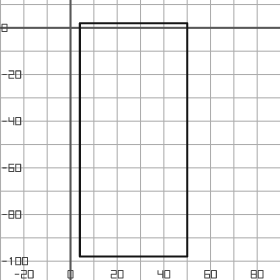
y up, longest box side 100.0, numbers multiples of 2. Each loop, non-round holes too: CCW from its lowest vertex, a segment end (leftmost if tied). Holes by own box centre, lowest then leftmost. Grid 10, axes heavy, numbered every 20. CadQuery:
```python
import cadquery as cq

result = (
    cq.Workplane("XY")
    .moveTo(4.0, -98.0)
    .lineTo(50.0, -98.0)
    .lineTo(50.0, 2.0)
    .lineTo(4.0, 2.0)
    .close()
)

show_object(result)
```